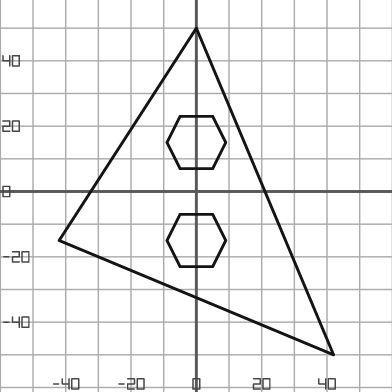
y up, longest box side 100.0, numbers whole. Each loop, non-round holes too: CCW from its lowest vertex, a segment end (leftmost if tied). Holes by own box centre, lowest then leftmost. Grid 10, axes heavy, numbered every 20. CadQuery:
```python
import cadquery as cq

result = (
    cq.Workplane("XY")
    .moveTo(42.0, -50.0)
    .lineTo(0.0, 50.0)
    .lineTo(-42.0, -15.0)
    .close()
    .moveTo(-5.0, -23.0)
    .lineTo(5.0, -23.0)
    .lineTo(9.0, -15.0)
    .lineTo(5.0, -7.0)
    .lineTo(-5.0, -7.0)
    .lineTo(-9.0, -15.0)
    .close()
    .moveTo(-5.0, 7.0)
    .lineTo(5.0, 7.0)
    .lineTo(9.0, 15.0)
    .lineTo(5.0, 23.0)
    .lineTo(-5.0, 23.0)
    .lineTo(-9.0, 15.0)
    .close()
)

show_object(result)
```